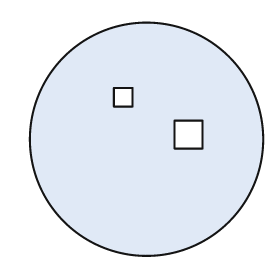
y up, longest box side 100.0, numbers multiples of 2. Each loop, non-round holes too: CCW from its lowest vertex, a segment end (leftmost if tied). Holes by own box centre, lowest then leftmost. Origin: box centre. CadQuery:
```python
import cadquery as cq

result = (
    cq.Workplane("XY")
    .moveTo(0.0, 0.0)
    .circle(50.0)
    .moveTo(12.0, -4.0)
    .lineTo(24.0, -4.0)
    .lineTo(24.0, 8.0)
    .lineTo(12.0, 8.0)
    .close()
    .moveTo(-14.0, 14.0)
    .lineTo(-6.0, 14.0)
    .lineTo(-6.0, 22.0)
    .lineTo(-14.0, 22.0)
    .close()
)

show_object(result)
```